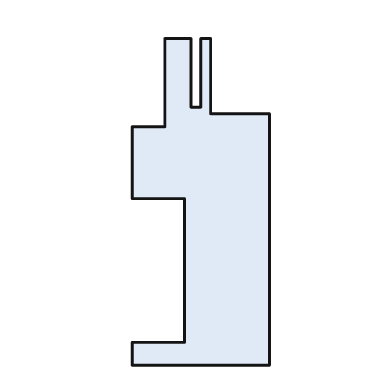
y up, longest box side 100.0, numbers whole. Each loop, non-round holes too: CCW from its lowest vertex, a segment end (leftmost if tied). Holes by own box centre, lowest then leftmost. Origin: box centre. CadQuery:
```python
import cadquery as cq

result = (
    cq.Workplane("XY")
    .moveTo(-21.0, -50.0)
    .lineTo(21.0, -50.0)
    .lineTo(21.0, 27.0)
    .lineTo(3.0, 27.0)
    .lineTo(3.0, 50.0)
    .lineTo(0.0, 50.0)
    .lineTo(0.0, 29.0)
    .lineTo(-3.0, 29.0)
    .lineTo(-3.0, 50.0)
    .lineTo(-11.0, 50.0)
    .lineTo(-11.0, 23.0)
    .lineTo(-21.0, 23.0)
    .lineTo(-21.0, 1.0)
    .lineTo(-5.0, 1.0)
    .lineTo(-5.0, -43.0)
    .lineTo(-21.0, -43.0)
    .close()
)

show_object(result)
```